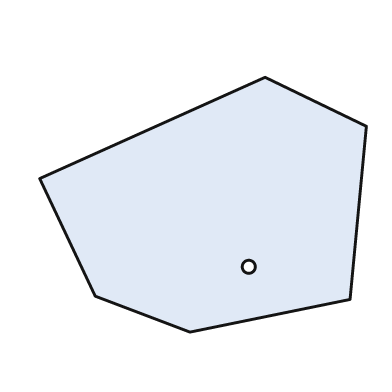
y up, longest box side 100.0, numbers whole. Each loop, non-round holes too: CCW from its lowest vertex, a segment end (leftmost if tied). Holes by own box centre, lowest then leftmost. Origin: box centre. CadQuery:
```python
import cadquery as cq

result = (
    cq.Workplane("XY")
    .moveTo(-4.0, -39.0)
    .lineTo(45.0, -29.0)
    .lineTo(50.0, 24.0)
    .lineTo(19.0, 39.0)
    .lineTo(-50.0, 8.0)
    .lineTo(-33.0, -28.0)
    .close()
    .moveTo(14.0, -19.0)
    .circle(2.0)
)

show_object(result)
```